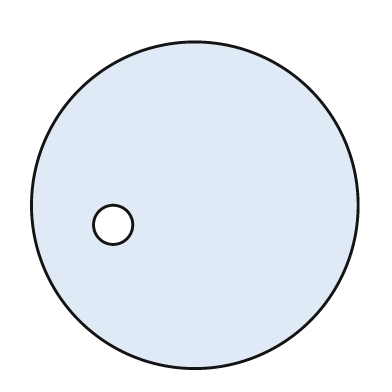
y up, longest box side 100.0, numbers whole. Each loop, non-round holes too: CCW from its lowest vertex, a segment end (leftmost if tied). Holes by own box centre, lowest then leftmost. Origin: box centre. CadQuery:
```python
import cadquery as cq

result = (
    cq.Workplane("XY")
    .moveTo(0.0, 0.0)
    .circle(50.0)
    .moveTo(-25.0, -6.0)
    .circle(6.0)
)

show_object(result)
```